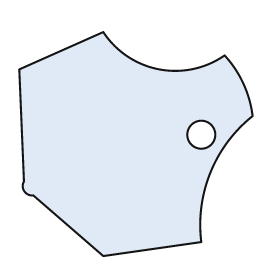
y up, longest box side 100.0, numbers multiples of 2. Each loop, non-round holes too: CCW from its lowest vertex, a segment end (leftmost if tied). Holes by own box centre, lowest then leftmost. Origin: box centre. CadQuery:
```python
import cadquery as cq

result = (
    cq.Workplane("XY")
    .moveTo(-14.0, -48.0)
    .lineTo(28.0, -42.0)
    .threePointArc((32.0, -12.0), (50.0, 12.0))
    .threePointArc((46.0, 26.0), (38.0, 38.0))
    .threePointArc((10.0, 32.0), (-14.0, 48.0))
    .lineTo(-50.0, 32.0)
    .lineTo(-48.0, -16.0)
    .threePointArc((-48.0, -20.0), (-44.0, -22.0))
    .close()
    .moveTo(28.0, 4.0)
    .circle(6.0)
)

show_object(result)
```